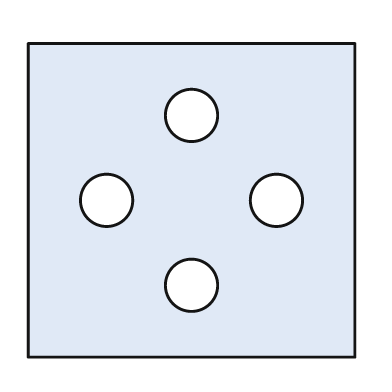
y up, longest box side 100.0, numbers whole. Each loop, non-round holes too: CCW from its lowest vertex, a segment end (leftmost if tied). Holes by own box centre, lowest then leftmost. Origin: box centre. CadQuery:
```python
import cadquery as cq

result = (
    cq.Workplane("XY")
    .moveTo(-50.0, -48.0)
    .lineTo(50.0, -48.0)
    .lineTo(50.0, 48.0)
    .lineTo(-50.0, 48.0)
    .close()
    .moveTo(0.0, -26.0)
    .circle(8.0)
    .moveTo(-26.0, 0.0)
    .circle(8.0)
    .moveTo(26.0, 0.0)
    .circle(8.0)
    .moveTo(0.0, 26.0)
    .circle(8.0)
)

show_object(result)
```